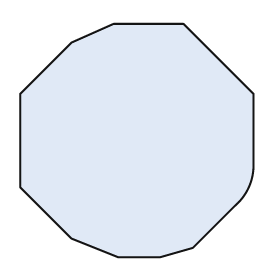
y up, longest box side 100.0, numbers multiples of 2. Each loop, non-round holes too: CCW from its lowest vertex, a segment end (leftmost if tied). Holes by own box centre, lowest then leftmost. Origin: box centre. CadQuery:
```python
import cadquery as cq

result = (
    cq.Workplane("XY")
    .moveTo(-8.0, -50.0)
    .lineTo(10.0, -50.0)
    .lineTo(24.0, -46.0)
    .lineTo(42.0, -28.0)
    .threePointArc((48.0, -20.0), (50.0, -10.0))
    .lineTo(50.0, 20.0)
    .lineTo(20.0, 50.0)
    .lineTo(-10.0, 50.0)
    .lineTo(-28.0, 42.0)
    .lineTo(-50.0, 20.0)
    .lineTo(-50.0, -20.0)
    .lineTo(-28.0, -42.0)
    .close()
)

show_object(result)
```